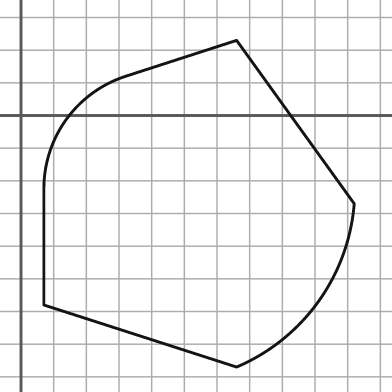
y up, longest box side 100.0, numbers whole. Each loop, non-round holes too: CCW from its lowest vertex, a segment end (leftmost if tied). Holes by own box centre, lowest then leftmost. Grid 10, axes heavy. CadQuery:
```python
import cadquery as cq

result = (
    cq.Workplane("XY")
    .moveTo(66.0, -77.0)
    .threePointArc((91.0, -57.0), (102.0, -27.0))
    .lineTo(66.0, 23.0)
    .lineTo(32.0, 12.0)
    .threePointArc((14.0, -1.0), (7.0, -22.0))
    .lineTo(7.0, -58.0)
    .close()
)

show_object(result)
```